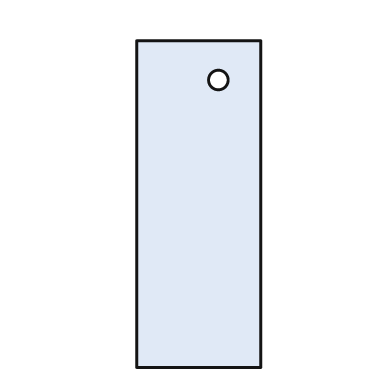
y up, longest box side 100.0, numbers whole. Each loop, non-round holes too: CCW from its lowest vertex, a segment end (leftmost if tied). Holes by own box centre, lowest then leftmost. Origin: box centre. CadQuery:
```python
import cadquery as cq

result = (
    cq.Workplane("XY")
    .moveTo(-19.0, -50.0)
    .lineTo(19.0, -50.0)
    .lineTo(19.0, 50.0)
    .lineTo(-19.0, 50.0)
    .close()
    .moveTo(6.0, 38.0)
    .circle(3.0)
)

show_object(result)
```